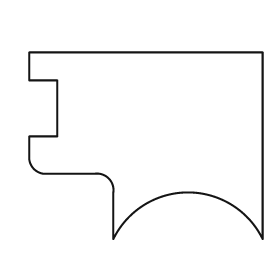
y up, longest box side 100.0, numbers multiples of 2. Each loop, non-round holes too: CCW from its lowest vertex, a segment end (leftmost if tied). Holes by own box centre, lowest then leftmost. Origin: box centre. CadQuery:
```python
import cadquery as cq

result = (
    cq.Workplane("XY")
    .moveTo(-14.0, -40.0)
    .threePointArc((18.0, -20.0), (50.0, -40.0))
    .lineTo(50.0, 40.0)
    .lineTo(-50.0, 40.0)
    .lineTo(-50.0, 28.0)
    .lineTo(-38.0, 28.0)
    .lineTo(-38.0, 4.0)
    .lineTo(-50.0, 4.0)
    .lineTo(-50.0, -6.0)
    .threePointArc((-48.0, -10.0), (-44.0, -12.0))
    .lineTo(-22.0, -12.0)
    .threePointArc((-16.0, -14.0), (-14.0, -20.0))
    .close()
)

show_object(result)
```